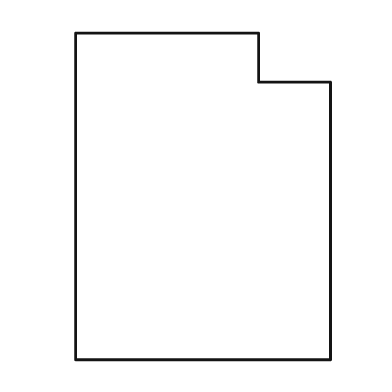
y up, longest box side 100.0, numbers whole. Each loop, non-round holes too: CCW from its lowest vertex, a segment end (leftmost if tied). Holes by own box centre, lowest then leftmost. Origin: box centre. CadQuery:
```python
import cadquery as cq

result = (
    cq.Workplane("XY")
    .moveTo(-39.0, -50.0)
    .lineTo(39.0, -50.0)
    .lineTo(39.0, 35.0)
    .lineTo(17.0, 35.0)
    .lineTo(17.0, 50.0)
    .lineTo(-39.0, 50.0)
    .close()
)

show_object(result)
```